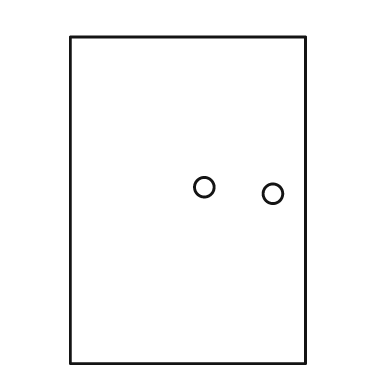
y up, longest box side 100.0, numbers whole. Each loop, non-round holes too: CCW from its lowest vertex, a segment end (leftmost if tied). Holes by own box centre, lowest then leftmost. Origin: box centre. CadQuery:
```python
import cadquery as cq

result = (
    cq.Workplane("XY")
    .moveTo(-36.0, -50.0)
    .lineTo(36.0, -50.0)
    .lineTo(36.0, 50.0)
    .lineTo(-36.0, 50.0)
    .close()
    .moveTo(26.0, 2.0)
    .circle(3.0)
    .moveTo(5.0, 4.0)
    .circle(3.0)
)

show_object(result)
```